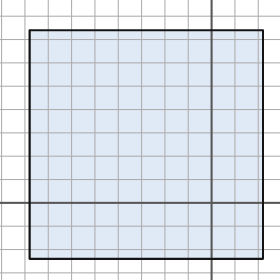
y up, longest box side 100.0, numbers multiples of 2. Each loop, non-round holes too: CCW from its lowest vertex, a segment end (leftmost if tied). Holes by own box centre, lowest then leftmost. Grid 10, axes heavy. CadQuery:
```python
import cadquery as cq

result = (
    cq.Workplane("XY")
    .moveTo(-78.0, -24.0)
    .lineTo(22.0, -24.0)
    .lineTo(22.0, 74.0)
    .lineTo(-78.0, 74.0)
    .close()
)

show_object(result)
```